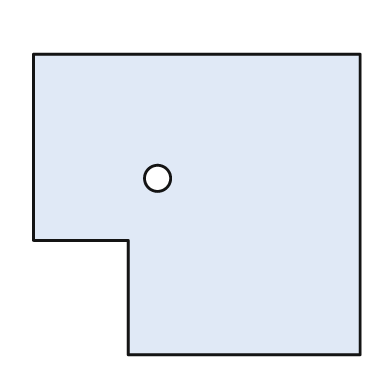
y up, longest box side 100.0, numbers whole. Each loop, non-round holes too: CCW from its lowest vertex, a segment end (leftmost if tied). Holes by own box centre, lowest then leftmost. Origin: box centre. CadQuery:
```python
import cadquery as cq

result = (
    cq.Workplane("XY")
    .moveTo(-21.0, -46.0)
    .lineTo(50.0, -46.0)
    .lineTo(50.0, 46.0)
    .lineTo(-50.0, 46.0)
    .lineTo(-50.0, -11.0)
    .lineTo(-21.0, -11.0)
    .close()
    .moveTo(-12.0, 8.0)
    .circle(4.0)
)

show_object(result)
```